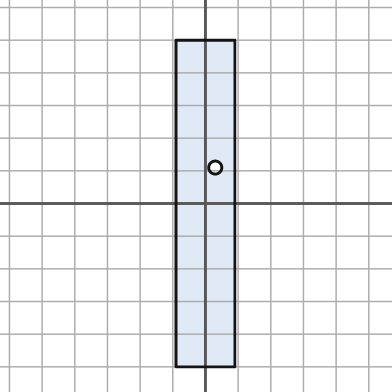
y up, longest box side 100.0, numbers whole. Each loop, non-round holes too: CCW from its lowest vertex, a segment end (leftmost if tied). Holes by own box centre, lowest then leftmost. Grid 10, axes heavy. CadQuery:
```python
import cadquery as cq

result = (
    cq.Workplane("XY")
    .moveTo(-9.0, -50.0)
    .lineTo(9.0, -50.0)
    .lineTo(9.0, 50.0)
    .lineTo(-9.0, 50.0)
    .close()
    .moveTo(3.0, 11.0)
    .circle(2.0)
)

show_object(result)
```